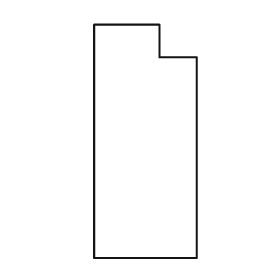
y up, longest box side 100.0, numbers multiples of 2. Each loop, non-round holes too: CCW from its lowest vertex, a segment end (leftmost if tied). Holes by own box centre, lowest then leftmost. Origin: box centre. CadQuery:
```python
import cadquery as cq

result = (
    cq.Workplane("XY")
    .moveTo(-22.0, -50.0)
    .lineTo(22.0, -50.0)
    .lineTo(22.0, 36.0)
    .lineTo(6.0, 36.0)
    .lineTo(6.0, 50.0)
    .lineTo(-22.0, 50.0)
    .close()
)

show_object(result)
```